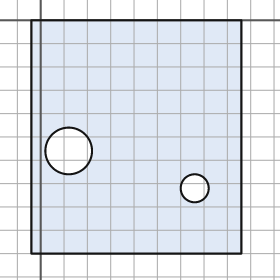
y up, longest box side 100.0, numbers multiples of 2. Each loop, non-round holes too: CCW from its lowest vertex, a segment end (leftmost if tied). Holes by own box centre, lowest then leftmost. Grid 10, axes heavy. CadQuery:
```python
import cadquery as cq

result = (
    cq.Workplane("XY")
    .moveTo(-4.0, -100.0)
    .lineTo(86.0, -100.0)
    .lineTo(86.0, 0.0)
    .lineTo(-4.0, 0.0)
    .close()
    .moveTo(66.0, -72.0)
    .circle(6.0)
    .moveTo(12.0, -56.0)
    .circle(10.0)
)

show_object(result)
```